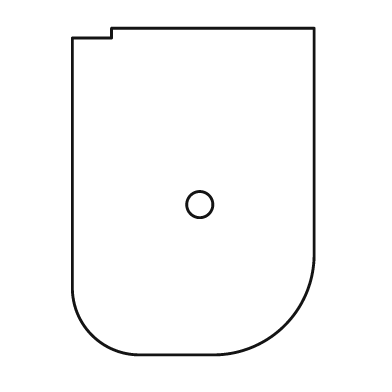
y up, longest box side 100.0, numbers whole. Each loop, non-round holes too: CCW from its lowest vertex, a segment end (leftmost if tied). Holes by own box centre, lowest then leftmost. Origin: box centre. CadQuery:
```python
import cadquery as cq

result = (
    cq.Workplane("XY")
    .moveTo(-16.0, -50.0)
    .lineTo(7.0, -50.0)
    .threePointArc((28.0, -41.0), (37.0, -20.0))
    .lineTo(37.0, 50.0)
    .lineTo(-25.0, 50.0)
    .lineTo(-25.0, 47.0)
    .lineTo(-37.0, 47.0)
    .lineTo(-37.0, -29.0)
    .threePointArc((-31.0, -44.0), (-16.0, -50.0))
    .close()
    .moveTo(2.0, -4.0)
    .circle(4.0)
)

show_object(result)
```